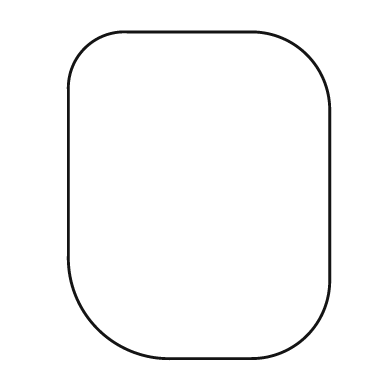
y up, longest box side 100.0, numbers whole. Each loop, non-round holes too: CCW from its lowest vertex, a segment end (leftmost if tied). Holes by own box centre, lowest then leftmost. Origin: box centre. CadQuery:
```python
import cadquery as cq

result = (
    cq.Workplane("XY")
    .moveTo(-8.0, -50.0)
    .lineTo(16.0, -50.0)
    .threePointArc((33.0, -43.0), (40.0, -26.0))
    .lineTo(40.0, 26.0)
    .threePointArc((33.0, 43.0), (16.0, 50.0))
    .lineTo(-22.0, 50.0)
    .threePointArc((-35.0, 45.0), (-40.0, 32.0))
    .lineTo(-40.0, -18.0)
    .threePointArc((-31.0, -41.0), (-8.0, -50.0))
    .close()
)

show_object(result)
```